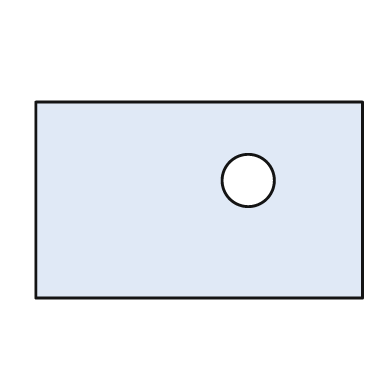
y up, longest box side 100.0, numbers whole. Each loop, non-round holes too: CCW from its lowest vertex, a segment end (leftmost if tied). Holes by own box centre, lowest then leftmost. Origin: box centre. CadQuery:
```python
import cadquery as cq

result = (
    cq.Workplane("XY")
    .moveTo(-50.0, -30.0)
    .lineTo(50.0, -30.0)
    .lineTo(50.0, 30.0)
    .lineTo(-50.0, 30.0)
    .close()
    .moveTo(15.0, 6.0)
    .circle(8.0)
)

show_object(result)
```